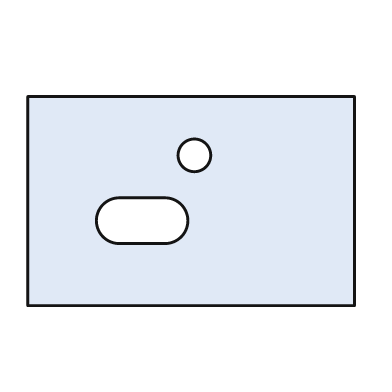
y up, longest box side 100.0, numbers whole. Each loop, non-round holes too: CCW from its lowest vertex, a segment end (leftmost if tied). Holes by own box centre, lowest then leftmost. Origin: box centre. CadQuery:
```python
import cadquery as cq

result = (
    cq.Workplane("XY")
    .moveTo(-50.0, -32.0)
    .lineTo(50.0, -32.0)
    .lineTo(50.0, 32.0)
    .lineTo(-50.0, 32.0)
    .close()
    .moveTo(-22.0, -13.0)
    .lineTo(-8.0, -13.0)
    .threePointArc((-1.0, -6.0), (-8.0, 1.0))
    .lineTo(-22.0, 1.0)
    .threePointArc((-29.0, -6.0), (-22.0, -13.0))
    .close()
    .moveTo(1.0, 14.0)
    .circle(5.0)
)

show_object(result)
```